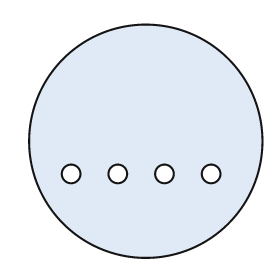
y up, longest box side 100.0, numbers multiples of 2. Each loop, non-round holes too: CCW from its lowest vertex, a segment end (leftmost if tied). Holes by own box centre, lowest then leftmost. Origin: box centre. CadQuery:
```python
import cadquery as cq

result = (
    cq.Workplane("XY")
    .moveTo(0.0, 0.0)
    .circle(50.0)
    .moveTo(-32.0, -14.0)
    .circle(4.0)
    .moveTo(-12.0, -14.0)
    .circle(4.0)
    .moveTo(8.0, -14.0)
    .circle(4.0)
    .moveTo(28.0, -14.0)
    .circle(4.0)
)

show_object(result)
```